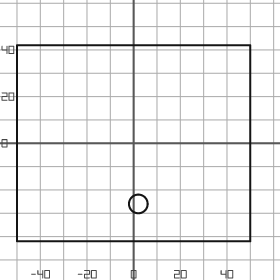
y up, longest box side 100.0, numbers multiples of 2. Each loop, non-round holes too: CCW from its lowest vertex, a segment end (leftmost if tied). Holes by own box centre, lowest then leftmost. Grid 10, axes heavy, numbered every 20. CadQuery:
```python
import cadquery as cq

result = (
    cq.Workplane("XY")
    .moveTo(-50.0, -42.0)
    .lineTo(50.0, -42.0)
    .lineTo(50.0, 42.0)
    .lineTo(-50.0, 42.0)
    .close()
    .moveTo(2.0, -26.0)
    .circle(4.0)
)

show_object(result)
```